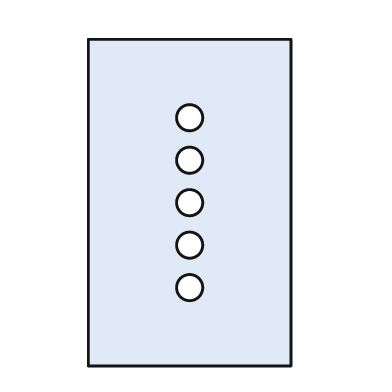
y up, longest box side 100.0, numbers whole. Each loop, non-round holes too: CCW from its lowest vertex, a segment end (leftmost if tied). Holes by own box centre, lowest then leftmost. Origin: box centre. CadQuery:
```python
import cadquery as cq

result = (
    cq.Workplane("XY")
    .moveTo(-31.0, -50.0)
    .lineTo(31.0, -50.0)
    .lineTo(31.0, 50.0)
    .lineTo(-31.0, 50.0)
    .close()
    .moveTo(0.0, -26.0)
    .circle(4.0)
    .moveTo(0.0, -13.0)
    .circle(4.0)
    .moveTo(0.0, 0.0)
    .circle(4.0)
    .moveTo(0.0, 13.0)
    .circle(4.0)
    .moveTo(0.0, 26.0)
    .circle(4.0)
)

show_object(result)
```